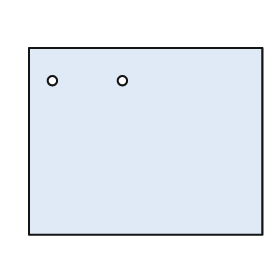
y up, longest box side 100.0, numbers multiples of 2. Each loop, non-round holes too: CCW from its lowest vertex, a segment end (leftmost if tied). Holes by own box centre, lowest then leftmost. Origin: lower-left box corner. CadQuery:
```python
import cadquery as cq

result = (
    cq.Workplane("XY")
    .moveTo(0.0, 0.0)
    .lineTo(100.0, 0.0)
    .lineTo(100.0, 80.0)
    .lineTo(0.0, 80.0)
    .close()
    .moveTo(10.0, 66.0)
    .circle(2.0)
    .moveTo(40.0, 66.0)
    .circle(2.0)
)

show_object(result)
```